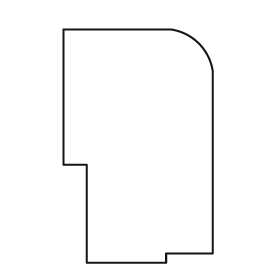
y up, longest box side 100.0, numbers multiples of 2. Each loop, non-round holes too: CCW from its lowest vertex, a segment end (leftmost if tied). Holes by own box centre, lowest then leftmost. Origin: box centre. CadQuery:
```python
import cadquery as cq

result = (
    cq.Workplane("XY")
    .moveTo(-22.0, -50.0)
    .lineTo(12.0, -50.0)
    .lineTo(12.0, -46.0)
    .lineTo(32.0, -46.0)
    .lineTo(32.0, 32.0)
    .threePointArc((26.0, 44.0), (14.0, 50.0))
    .lineTo(-32.0, 50.0)
    .lineTo(-32.0, -8.0)
    .lineTo(-22.0, -8.0)
    .close()
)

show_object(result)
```